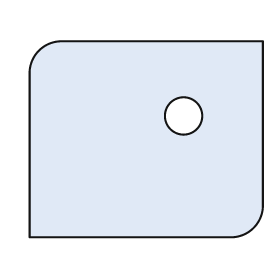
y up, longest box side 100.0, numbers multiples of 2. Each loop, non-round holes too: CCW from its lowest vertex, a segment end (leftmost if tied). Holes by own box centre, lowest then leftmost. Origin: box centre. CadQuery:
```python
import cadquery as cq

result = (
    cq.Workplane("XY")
    .moveTo(-50.0, -42.0)
    .lineTo(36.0, -42.0)
    .threePointArc((46.0, -38.0), (50.0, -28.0))
    .lineTo(50.0, 42.0)
    .lineTo(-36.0, 42.0)
    .threePointArc((-46.0, 38.0), (-50.0, 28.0))
    .close()
    .moveTo(16.0, 10.0)
    .circle(8.0)
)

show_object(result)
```